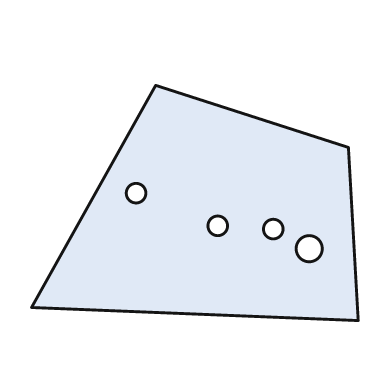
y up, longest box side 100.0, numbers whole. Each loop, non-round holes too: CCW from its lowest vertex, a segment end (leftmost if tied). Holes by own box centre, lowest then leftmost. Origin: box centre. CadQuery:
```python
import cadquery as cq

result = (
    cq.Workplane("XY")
    .moveTo(50.0, -36.0)
    .lineTo(47.0, 17.0)
    .lineTo(-12.0, 36.0)
    .lineTo(-50.0, -32.0)
    .close()
    .moveTo(35.0, -14.0)
    .circle(4.0)
    .moveTo(24.0, -8.0)
    .circle(3.0)
    .moveTo(7.0, -7.0)
    .circle(3.0)
    .moveTo(-18.0, 3.0)
    .circle(3.0)
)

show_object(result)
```